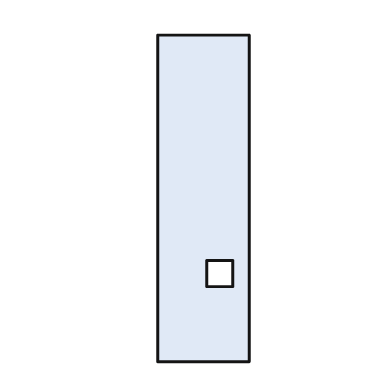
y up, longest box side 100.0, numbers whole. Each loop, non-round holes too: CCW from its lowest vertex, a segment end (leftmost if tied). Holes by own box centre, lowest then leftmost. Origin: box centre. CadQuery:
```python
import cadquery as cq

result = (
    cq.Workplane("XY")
    .moveTo(-14.0, -50.0)
    .lineTo(14.0, -50.0)
    .lineTo(14.0, 50.0)
    .lineTo(-14.0, 50.0)
    .close()
    .moveTo(1.0, -27.0)
    .lineTo(9.0, -27.0)
    .lineTo(9.0, -19.0)
    .lineTo(1.0, -19.0)
    .close()
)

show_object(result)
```